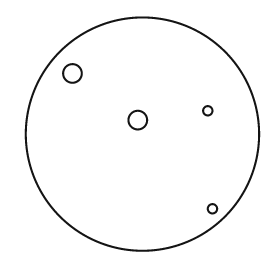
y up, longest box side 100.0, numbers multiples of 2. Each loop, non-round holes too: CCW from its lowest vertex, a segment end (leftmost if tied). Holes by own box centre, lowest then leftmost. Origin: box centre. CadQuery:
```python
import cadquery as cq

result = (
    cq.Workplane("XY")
    .moveTo(0.0, 0.0)
    .circle(50.0)
    .moveTo(30.0, -32.0)
    .circle(2.0)
    .moveTo(-2.0, 6.0)
    .circle(4.0)
    .moveTo(28.0, 10.0)
    .circle(2.0)
    .moveTo(-30.0, 26.0)
    .circle(4.0)
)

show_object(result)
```